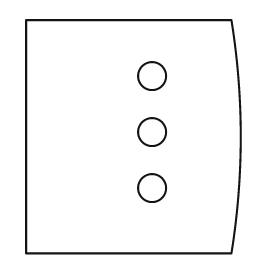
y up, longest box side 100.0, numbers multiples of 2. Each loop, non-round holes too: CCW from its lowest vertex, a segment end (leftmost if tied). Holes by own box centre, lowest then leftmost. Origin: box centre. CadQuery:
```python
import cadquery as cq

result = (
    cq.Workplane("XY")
    .moveTo(-46.0, -50.0)
    .lineTo(42.0, -50.0)
    .threePointArc((46.0, 0.0), (42.0, 50.0))
    .lineTo(-46.0, 50.0)
    .close()
    .moveTo(8.0, -22.0)
    .circle(6.0)
    .moveTo(8.0, 2.0)
    .circle(6.0)
    .moveTo(8.0, 26.0)
    .circle(6.0)
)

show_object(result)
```